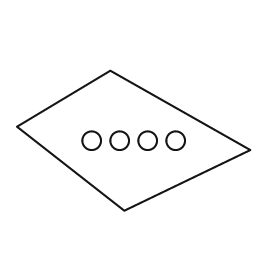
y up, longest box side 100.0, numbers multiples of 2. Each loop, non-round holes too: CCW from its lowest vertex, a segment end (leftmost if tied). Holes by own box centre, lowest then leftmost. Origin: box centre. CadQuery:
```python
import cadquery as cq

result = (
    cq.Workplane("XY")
    .moveTo(-4.0, -30.0)
    .lineTo(50.0, -4.0)
    .lineTo(-10.0, 30.0)
    .lineTo(-50.0, 6.0)
    .close()
    .moveTo(-18.0, 0.0)
    .circle(4.0)
    .moveTo(-6.0, 0.0)
    .circle(4.0)
    .moveTo(6.0, 0.0)
    .circle(4.0)
    .moveTo(18.0, 0.0)
    .circle(4.0)
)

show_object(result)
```